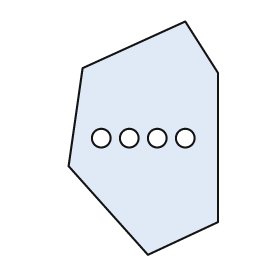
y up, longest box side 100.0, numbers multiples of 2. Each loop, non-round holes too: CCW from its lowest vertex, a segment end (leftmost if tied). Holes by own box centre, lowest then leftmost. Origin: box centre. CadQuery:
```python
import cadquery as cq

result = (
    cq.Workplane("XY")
    .moveTo(2.0, -50.0)
    .lineTo(32.0, -36.0)
    .lineTo(32.0, 28.0)
    .lineTo(18.0, 50.0)
    .lineTo(-26.0, 30.0)
    .lineTo(-32.0, -12.0)
    .close()
    .moveTo(-18.0, 0.0)
    .circle(4.0)
    .moveTo(-6.0, 0.0)
    .circle(4.0)
    .moveTo(6.0, 0.0)
    .circle(4.0)
    .moveTo(18.0, 0.0)
    .circle(4.0)
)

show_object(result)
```